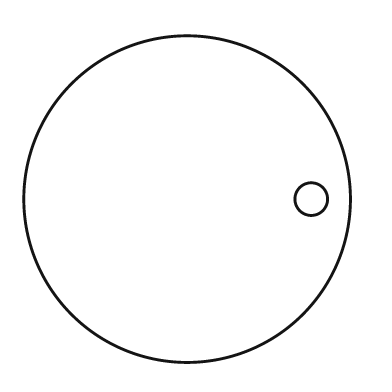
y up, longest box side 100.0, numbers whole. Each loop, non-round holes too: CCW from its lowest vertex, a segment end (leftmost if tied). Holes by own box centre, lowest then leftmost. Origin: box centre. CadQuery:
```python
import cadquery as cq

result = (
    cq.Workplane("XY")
    .moveTo(0.0, 0.0)
    .circle(50.0)
    .moveTo(38.0, 0.0)
    .circle(5.0)
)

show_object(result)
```